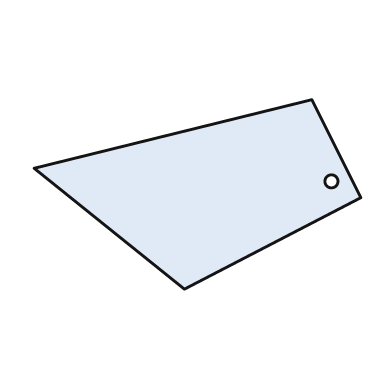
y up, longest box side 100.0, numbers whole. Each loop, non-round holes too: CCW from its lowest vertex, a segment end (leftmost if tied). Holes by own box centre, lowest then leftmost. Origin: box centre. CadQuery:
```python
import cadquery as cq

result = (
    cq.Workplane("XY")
    .moveTo(-4.0, -29.0)
    .lineTo(50.0, -1.0)
    .lineTo(35.0, 29.0)
    .lineTo(-50.0, 8.0)
    .close()
    .moveTo(41.0, 4.0)
    .circle(2.0)
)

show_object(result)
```